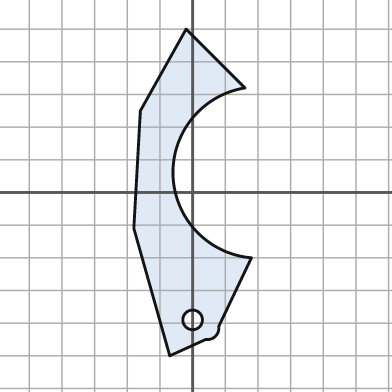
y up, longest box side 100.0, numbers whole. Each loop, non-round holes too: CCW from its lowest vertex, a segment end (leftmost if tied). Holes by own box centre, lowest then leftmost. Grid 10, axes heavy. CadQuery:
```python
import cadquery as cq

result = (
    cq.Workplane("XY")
    .moveTo(-7.0, -50.0)
    .lineTo(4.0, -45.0)
    .threePointArc((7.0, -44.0), (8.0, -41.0))
    .lineTo(18.0, -20.0)
    .threePointArc((-6.0, 5.0), (16.0, 32.0))
    .lineTo(-2.0, 50.0)
    .lineTo(-16.0, 25.0)
    .lineTo(-18.0, -11.0)
    .close()
    .moveTo(0.0, -39.0)
    .circle(3.0)
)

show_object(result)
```